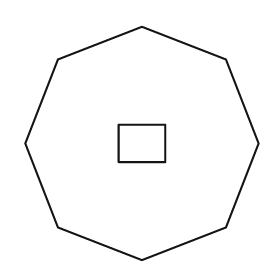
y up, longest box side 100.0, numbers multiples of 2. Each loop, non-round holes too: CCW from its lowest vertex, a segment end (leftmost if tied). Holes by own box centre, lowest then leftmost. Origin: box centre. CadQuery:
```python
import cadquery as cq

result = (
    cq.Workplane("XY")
    .moveTo(0.0, -50.0)
    .lineTo(36.0, -36.0)
    .lineTo(50.0, 0.0)
    .lineTo(36.0, 36.0)
    .lineTo(0.0, 50.0)
    .lineTo(-36.0, 36.0)
    .lineTo(-50.0, 0.0)
    .lineTo(-36.0, -36.0)
    .close()
    .moveTo(-10.0, -8.0)
    .lineTo(10.0, -8.0)
    .lineTo(10.0, 8.0)
    .lineTo(-10.0, 8.0)
    .close()
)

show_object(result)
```